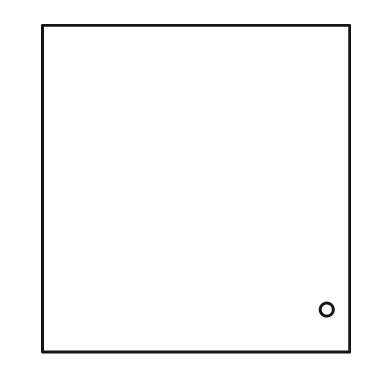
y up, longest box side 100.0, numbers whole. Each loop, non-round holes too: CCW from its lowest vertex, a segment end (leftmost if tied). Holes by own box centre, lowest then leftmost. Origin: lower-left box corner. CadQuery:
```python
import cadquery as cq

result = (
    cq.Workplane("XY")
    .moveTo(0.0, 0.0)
    .lineTo(94.0, 0.0)
    .lineTo(94.0, 100.0)
    .lineTo(0.0, 100.0)
    .close()
    .moveTo(87.0, 13.0)
    .circle(2.0)
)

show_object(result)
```